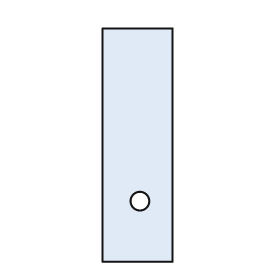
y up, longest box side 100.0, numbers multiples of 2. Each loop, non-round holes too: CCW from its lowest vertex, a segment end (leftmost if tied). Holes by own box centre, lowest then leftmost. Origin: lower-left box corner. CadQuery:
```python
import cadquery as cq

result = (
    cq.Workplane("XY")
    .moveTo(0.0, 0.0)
    .lineTo(30.0, 0.0)
    .lineTo(30.0, 100.0)
    .lineTo(0.0, 100.0)
    .close()
    .moveTo(16.0, 26.0)
    .circle(4.0)
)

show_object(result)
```